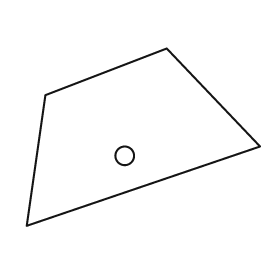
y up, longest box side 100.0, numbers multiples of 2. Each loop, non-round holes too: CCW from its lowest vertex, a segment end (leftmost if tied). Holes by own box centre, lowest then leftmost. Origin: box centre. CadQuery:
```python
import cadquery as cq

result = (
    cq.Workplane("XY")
    .moveTo(-50.0, -38.0)
    .lineTo(50.0, -4.0)
    .lineTo(10.0, 38.0)
    .lineTo(-42.0, 18.0)
    .close()
    .moveTo(-8.0, -8.0)
    .circle(4.0)
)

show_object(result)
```